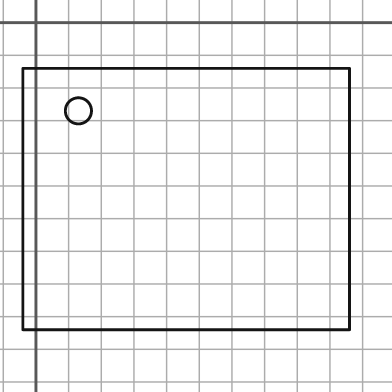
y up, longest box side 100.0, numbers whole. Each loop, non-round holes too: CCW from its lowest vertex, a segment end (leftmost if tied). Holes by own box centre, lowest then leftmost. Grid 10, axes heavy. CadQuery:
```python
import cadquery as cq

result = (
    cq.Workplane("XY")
    .moveTo(-4.0, -94.0)
    .lineTo(96.0, -94.0)
    .lineTo(96.0, -14.0)
    .lineTo(-4.0, -14.0)
    .close()
    .moveTo(13.0, -27.0)
    .circle(4.0)
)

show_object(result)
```